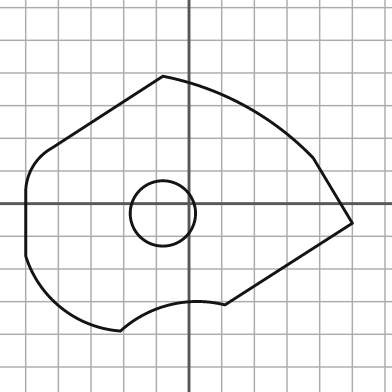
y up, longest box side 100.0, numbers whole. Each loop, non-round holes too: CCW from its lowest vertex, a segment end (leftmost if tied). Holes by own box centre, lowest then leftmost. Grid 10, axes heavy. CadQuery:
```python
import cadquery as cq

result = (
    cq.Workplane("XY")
    .moveTo(-21.0, -39.0)
    .threePointArc((-6.0, -31.0), (11.0, -31.0))
    .lineTo(50.0, -6.0)
    .lineTo(38.0, 14.0)
    .threePointArc((17.0, 30.0), (-8.0, 39.0))
    .lineTo(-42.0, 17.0)
    .threePointArc((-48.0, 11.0), (-50.0, 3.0))
    .lineTo(-50.0, -16.0)
    .threePointArc((-39.0, -32.0), (-21.0, -39.0))
    .close()
    .moveTo(-8.0, -3.0)
    .circle(10.0)
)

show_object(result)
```